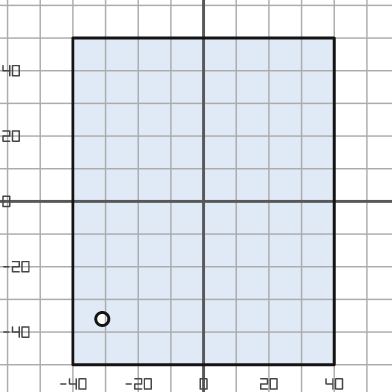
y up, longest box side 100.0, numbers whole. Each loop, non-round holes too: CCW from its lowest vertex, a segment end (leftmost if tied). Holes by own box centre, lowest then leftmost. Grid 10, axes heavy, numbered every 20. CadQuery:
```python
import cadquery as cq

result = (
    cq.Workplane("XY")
    .moveTo(-40.0, -50.0)
    .lineTo(40.0, -50.0)
    .lineTo(40.0, 50.0)
    .lineTo(-40.0, 50.0)
    .close()
    .moveTo(-31.0, -36.0)
    .circle(2.0)
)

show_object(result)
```